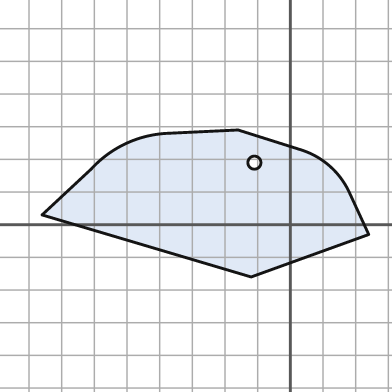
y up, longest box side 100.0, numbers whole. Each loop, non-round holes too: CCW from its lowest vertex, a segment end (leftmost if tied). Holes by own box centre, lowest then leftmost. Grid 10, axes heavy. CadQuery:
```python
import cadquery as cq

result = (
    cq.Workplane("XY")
    .moveTo(-12.0, -16.0)
    .lineTo(24.0, -3.0)
    .lineTo(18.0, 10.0)
    .threePointArc((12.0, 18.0), (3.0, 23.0))
    .lineTo(-16.0, 29.0)
    .lineTo(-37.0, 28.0)
    .threePointArc((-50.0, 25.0), (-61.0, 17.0))
    .lineTo(-76.0, 3.0)
    .close()
    .moveTo(-11.0, 19.0)
    .circle(2.0)
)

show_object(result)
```